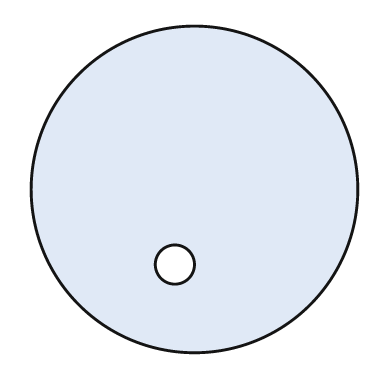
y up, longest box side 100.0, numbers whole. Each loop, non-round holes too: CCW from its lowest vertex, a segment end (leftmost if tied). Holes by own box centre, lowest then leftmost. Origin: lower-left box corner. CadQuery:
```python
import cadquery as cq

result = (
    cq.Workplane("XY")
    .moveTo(50.0, 50.0)
    .circle(50.0)
    .moveTo(44.0, 27.0)
    .circle(6.0)
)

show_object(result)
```